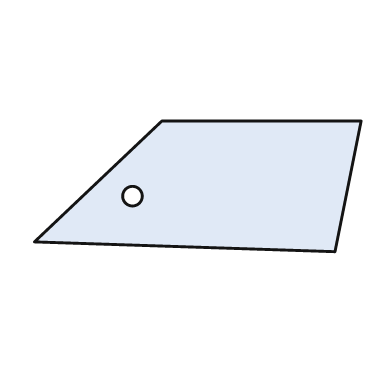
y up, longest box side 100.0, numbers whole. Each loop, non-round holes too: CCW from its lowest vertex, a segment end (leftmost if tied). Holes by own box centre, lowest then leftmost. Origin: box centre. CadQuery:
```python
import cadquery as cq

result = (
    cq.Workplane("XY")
    .moveTo(42.0, -20.0)
    .lineTo(50.0, 20.0)
    .lineTo(-11.0, 20.0)
    .lineTo(-50.0, -17.0)
    .close()
    .moveTo(-20.0, -3.0)
    .circle(3.0)
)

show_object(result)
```